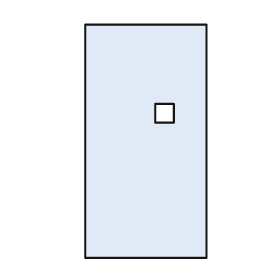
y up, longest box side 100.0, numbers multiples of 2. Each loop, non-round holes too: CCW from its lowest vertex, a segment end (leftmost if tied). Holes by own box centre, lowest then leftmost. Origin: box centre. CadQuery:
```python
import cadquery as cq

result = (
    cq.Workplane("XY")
    .moveTo(-26.0, -50.0)
    .lineTo(26.0, -50.0)
    .lineTo(26.0, 50.0)
    .lineTo(-26.0, 50.0)
    .close()
    .moveTo(4.0, 8.0)
    .lineTo(12.0, 8.0)
    .lineTo(12.0, 16.0)
    .lineTo(4.0, 16.0)
    .close()
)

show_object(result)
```